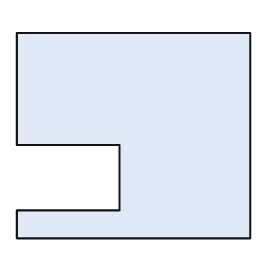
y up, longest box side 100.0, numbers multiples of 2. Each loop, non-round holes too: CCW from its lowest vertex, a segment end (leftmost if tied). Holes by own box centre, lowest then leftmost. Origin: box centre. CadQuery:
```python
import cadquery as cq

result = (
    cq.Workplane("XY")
    .moveTo(-50.0, -44.0)
    .lineTo(50.0, -44.0)
    .lineTo(50.0, 44.0)
    .lineTo(-50.0, 44.0)
    .lineTo(-50.0, -4.0)
    .lineTo(-6.0, -4.0)
    .lineTo(-6.0, -32.0)
    .lineTo(-50.0, -32.0)
    .close()
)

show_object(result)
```